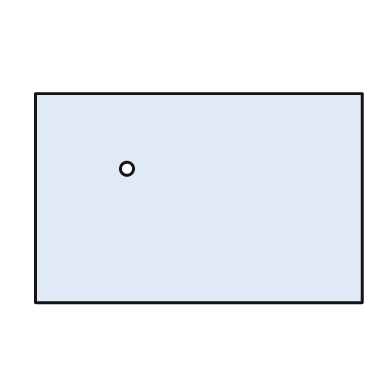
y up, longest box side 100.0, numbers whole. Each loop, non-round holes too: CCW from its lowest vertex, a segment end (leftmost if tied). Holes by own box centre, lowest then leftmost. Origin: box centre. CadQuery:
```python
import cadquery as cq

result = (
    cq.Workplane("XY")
    .moveTo(-50.0, -32.0)
    .lineTo(50.0, -32.0)
    .lineTo(50.0, 32.0)
    .lineTo(-50.0, 32.0)
    .close()
    .moveTo(-22.0, 9.0)
    .circle(2.0)
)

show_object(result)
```